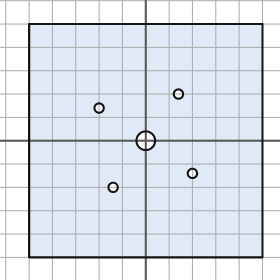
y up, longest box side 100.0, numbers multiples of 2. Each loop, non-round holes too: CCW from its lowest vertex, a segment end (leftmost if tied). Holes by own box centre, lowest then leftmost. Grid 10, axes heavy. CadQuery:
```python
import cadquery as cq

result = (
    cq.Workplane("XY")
    .moveTo(-50.0, -50.0)
    .lineTo(50.0, -50.0)
    .lineTo(50.0, 50.0)
    .lineTo(-50.0, 50.0)
    .close()
    .moveTo(-14.0, -20.0)
    .circle(2.0)
    .moveTo(20.0, -14.0)
    .circle(2.0)
    .moveTo(0.0, 0.0)
    .circle(4.0)
    .moveTo(-20.0, 14.0)
    .circle(2.0)
    .moveTo(14.0, 20.0)
    .circle(2.0)
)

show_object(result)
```